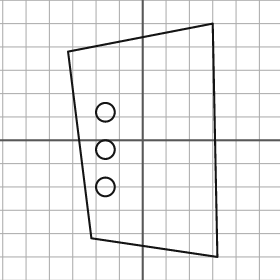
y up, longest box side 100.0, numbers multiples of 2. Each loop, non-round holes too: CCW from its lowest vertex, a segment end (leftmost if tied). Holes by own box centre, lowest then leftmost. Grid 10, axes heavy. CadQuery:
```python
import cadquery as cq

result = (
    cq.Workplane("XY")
    .moveTo(32.0, -50.0)
    .lineTo(30.0, 50.0)
    .lineTo(-32.0, 38.0)
    .lineTo(-22.0, -42.0)
    .close()
    .moveTo(-16.0, -20.0)
    .circle(4.0)
    .moveTo(-16.0, -4.0)
    .circle(4.0)
    .moveTo(-16.0, 12.0)
    .circle(4.0)
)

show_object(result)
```